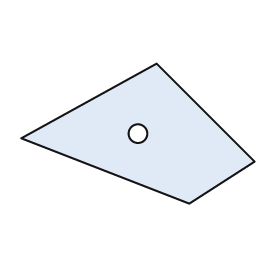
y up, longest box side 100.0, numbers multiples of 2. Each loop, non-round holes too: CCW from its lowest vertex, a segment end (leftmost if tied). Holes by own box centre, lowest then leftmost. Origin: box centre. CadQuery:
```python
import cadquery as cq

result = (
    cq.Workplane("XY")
    .moveTo(22.0, -30.0)
    .lineTo(50.0, -12.0)
    .lineTo(8.0, 30.0)
    .lineTo(-50.0, -2.0)
    .close()
    .moveTo(0.0, 0.0)
    .circle(4.0)
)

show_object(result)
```